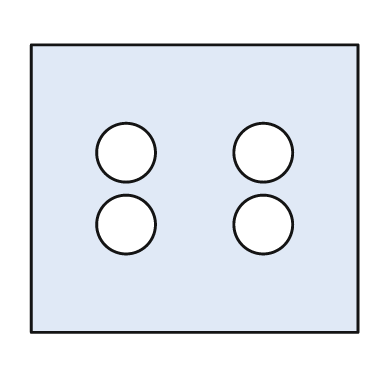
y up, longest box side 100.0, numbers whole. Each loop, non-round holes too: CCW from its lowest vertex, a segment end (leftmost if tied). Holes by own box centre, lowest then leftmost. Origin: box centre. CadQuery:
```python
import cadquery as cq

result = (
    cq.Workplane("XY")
    .moveTo(-50.0, -44.0)
    .lineTo(50.0, -44.0)
    .lineTo(50.0, 44.0)
    .lineTo(-50.0, 44.0)
    .close()
    .moveTo(-21.0, -11.0)
    .circle(9.0)
    .moveTo(21.0, -11.0)
    .circle(9.0)
    .moveTo(-21.0, 11.0)
    .circle(9.0)
    .moveTo(21.0, 11.0)
    .circle(9.0)
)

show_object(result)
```